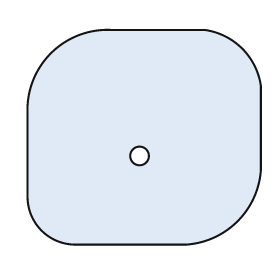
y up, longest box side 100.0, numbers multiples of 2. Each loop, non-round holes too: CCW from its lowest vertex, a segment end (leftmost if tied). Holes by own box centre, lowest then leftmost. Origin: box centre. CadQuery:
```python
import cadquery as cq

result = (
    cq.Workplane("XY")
    .moveTo(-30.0, -46.0)
    .lineTo(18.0, -46.0)
    .threePointArc((40.0, -36.0), (50.0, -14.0))
    .lineTo(50.0, 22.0)
    .threePointArc((42.0, 38.0), (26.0, 46.0))
    .lineTo(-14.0, 46.0)
    .threePointArc((-40.0, 36.0), (-50.0, 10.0))
    .lineTo(-50.0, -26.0)
    .threePointArc((-44.0, -40.0), (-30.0, -46.0))
    .close()
    .moveTo(-2.0, -8.0)
    .circle(4.0)
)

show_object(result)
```